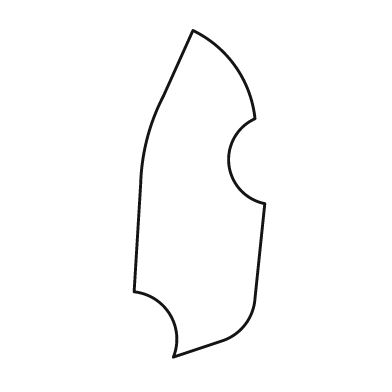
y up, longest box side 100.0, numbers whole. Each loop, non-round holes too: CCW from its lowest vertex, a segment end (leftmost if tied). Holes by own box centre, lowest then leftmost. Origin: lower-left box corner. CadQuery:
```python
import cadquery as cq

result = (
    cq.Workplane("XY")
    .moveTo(12.0, 0.0)
    .lineTo(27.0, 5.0)
    .threePointArc((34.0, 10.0), (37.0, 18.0))
    .lineTo(40.0, 47.0)
    .threePointArc((29.0, 59.0), (37.0, 73.0))
    .threePointArc((31.0, 89.0), (18.0, 100.0))
    .lineTo(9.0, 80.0)
    .threePointArc((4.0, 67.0), (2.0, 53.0))
    .lineTo(0.0, 20.0)
    .threePointArc((11.0, 13.0), (12.0, 0.0))
    .close()
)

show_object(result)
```